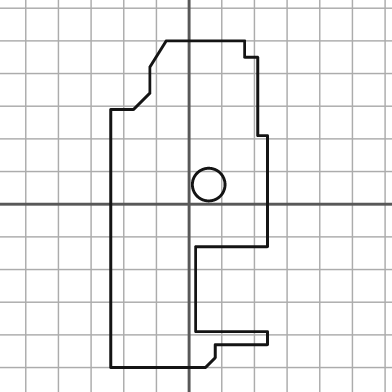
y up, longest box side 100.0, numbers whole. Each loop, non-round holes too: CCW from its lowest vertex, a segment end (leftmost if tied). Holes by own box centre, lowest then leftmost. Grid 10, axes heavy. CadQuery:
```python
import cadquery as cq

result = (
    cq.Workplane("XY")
    .moveTo(-24.0, -50.0)
    .lineTo(5.0, -50.0)
    .lineTo(8.0, -47.0)
    .lineTo(8.0, -43.0)
    .lineTo(24.0, -43.0)
    .lineTo(24.0, -39.0)
    .lineTo(2.0, -39.0)
    .lineTo(2.0, -13.0)
    .lineTo(24.0, -13.0)
    .lineTo(24.0, 21.0)
    .lineTo(21.0, 21.0)
    .lineTo(21.0, 45.0)
    .lineTo(17.0, 45.0)
    .lineTo(17.0, 50.0)
    .lineTo(-7.0, 50.0)
    .lineTo(-12.0, 42.0)
    .lineTo(-12.0, 34.0)
    .lineTo(-17.0, 29.0)
    .lineTo(-24.0, 29.0)
    .close()
    .moveTo(6.0, 6.0)
    .circle(5.0)
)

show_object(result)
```